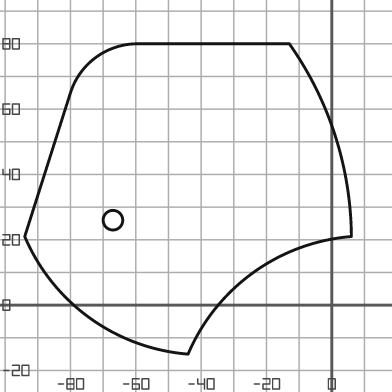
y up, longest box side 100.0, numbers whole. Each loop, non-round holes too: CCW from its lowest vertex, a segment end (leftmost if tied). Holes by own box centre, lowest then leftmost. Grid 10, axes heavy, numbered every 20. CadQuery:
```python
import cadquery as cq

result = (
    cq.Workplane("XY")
    .moveTo(-44.0, -15.0)
    .threePointArc((-24.0, 10.0), (6.0, 21.0))
    .threePointArc((1.0, 52.0), (-13.0, 80.0))
    .lineTo(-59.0, 80.0)
    .threePointArc((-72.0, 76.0), (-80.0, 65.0))
    .lineTo(-94.0, 21.0)
    .threePointArc((-74.0, -4.0), (-44.0, -15.0))
    .close()
    .moveTo(-67.0, 26.0)
    .circle(3.0)
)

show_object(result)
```